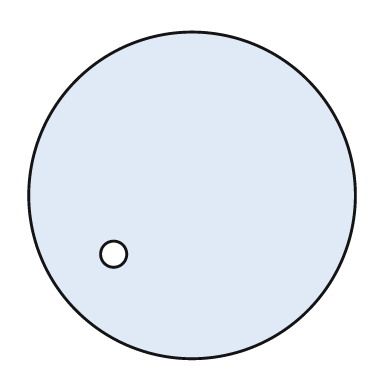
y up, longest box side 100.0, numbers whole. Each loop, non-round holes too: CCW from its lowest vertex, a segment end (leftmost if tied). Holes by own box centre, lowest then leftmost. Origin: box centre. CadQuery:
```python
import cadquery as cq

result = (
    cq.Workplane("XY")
    .moveTo(0.0, 0.0)
    .circle(50.0)
    .moveTo(-24.0, -18.0)
    .circle(4.0)
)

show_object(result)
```